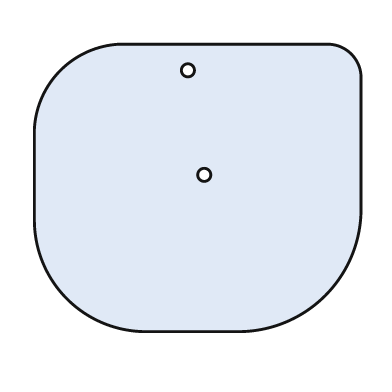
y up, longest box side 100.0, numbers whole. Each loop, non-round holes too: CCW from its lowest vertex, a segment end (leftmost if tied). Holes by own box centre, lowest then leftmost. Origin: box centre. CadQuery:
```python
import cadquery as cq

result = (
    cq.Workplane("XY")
    .moveTo(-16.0, -44.0)
    .lineTo(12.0, -44.0)
    .threePointArc((39.0, -33.0), (50.0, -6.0))
    .lineTo(50.0, 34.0)
    .threePointArc((47.0, 41.0), (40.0, 44.0))
    .lineTo(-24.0, 44.0)
    .threePointArc((-42.0, 36.0), (-50.0, 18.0))
    .lineTo(-50.0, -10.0)
    .threePointArc((-40.0, -34.0), (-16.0, -44.0))
    .close()
    .moveTo(2.0, 4.0)
    .circle(2.0)
    .moveTo(-3.0, 36.0)
    .circle(2.0)
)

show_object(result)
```